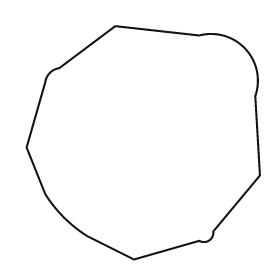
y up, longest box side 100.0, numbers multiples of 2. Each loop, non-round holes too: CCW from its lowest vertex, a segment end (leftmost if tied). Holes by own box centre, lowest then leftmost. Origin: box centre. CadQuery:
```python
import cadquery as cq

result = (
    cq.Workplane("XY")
    .moveTo(-4.0, -50.0)
    .lineTo(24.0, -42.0)
    .threePointArc((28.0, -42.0), (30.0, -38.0))
    .lineTo(50.0, -14.0)
    .lineTo(48.0, 20.0)
    .threePointArc((44.0, 40.0), (24.0, 46.0))
    .lineTo(-12.0, 50.0)
    .lineTo(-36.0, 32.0)
    .threePointArc((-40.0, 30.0), (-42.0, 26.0))
    .lineTo(-50.0, -2.0)
    .lineTo(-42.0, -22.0)
    .threePointArc((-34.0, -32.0), (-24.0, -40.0))
    .close()
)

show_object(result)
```